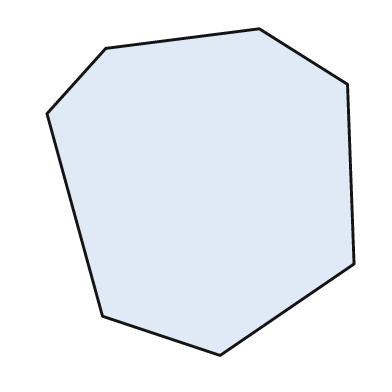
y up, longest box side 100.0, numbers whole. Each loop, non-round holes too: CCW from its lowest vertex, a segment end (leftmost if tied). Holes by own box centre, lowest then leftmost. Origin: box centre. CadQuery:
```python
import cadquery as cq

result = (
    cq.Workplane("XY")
    .moveTo(6.0, -50.0)
    .lineTo(47.0, -22.0)
    .lineTo(45.0, 33.0)
    .lineTo(18.0, 50.0)
    .lineTo(-29.0, 44.0)
    .lineTo(-47.0, 24.0)
    .lineTo(-30.0, -38.0)
    .close()
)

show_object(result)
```